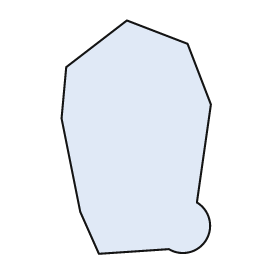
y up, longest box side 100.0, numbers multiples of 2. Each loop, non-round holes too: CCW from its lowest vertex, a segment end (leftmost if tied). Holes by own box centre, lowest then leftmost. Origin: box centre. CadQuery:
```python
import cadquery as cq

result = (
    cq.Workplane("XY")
    .moveTo(-16.0, -50.0)
    .lineTo(14.0, -48.0)
    .threePointArc((30.0, -44.0), (26.0, -28.0))
    .lineTo(32.0, 14.0)
    .lineTo(22.0, 40.0)
    .lineTo(-4.0, 50.0)
    .lineTo(-30.0, 30.0)
    .lineTo(-32.0, 8.0)
    .lineTo(-24.0, -32.0)
    .close()
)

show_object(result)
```